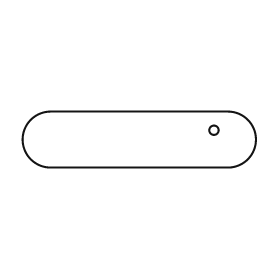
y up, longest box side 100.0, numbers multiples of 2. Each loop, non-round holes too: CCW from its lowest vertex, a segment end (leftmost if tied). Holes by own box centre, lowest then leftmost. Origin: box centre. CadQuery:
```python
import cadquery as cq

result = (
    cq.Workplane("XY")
    .moveTo(-38.0, -12.0)
    .lineTo(38.0, -12.0)
    .threePointArc((50.0, 0.0), (38.0, 12.0))
    .lineTo(-38.0, 12.0)
    .threePointArc((-50.0, 0.0), (-38.0, -12.0))
    .close()
    .moveTo(32.0, 4.0)
    .circle(2.0)
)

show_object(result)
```